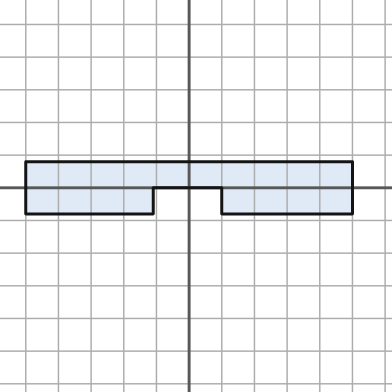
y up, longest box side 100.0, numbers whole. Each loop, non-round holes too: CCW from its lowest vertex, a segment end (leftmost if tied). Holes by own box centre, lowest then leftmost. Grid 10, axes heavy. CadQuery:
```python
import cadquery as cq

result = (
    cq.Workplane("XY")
    .moveTo(-50.0, -8.0)
    .lineTo(-11.0, -8.0)
    .lineTo(-11.0, 0.0)
    .lineTo(10.0, 0.0)
    .lineTo(10.0, -8.0)
    .lineTo(50.0, -8.0)
    .lineTo(50.0, 8.0)
    .lineTo(-50.0, 8.0)
    .close()
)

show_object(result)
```